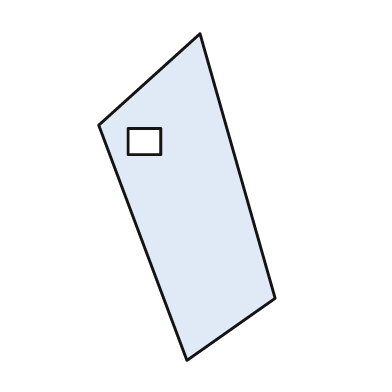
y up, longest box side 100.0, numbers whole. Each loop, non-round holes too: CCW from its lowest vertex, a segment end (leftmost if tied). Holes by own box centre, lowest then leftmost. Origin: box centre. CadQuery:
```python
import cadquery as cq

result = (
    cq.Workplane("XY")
    .moveTo(0.0, -50.0)
    .lineTo(27.0, -31.0)
    .lineTo(4.0, 50.0)
    .lineTo(-27.0, 22.0)
    .close()
    .moveTo(-18.0, 13.0)
    .lineTo(-8.0, 13.0)
    .lineTo(-8.0, 21.0)
    .lineTo(-18.0, 21.0)
    .close()
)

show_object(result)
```